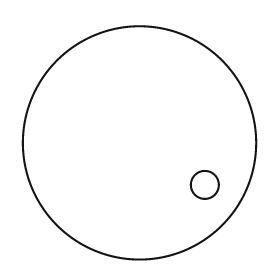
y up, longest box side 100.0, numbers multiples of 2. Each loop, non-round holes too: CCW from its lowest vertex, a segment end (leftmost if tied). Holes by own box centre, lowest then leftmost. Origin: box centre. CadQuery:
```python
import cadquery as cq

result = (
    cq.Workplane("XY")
    .moveTo(0.0, 0.0)
    .circle(50.0)
    .moveTo(28.0, -18.0)
    .circle(6.0)
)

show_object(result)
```